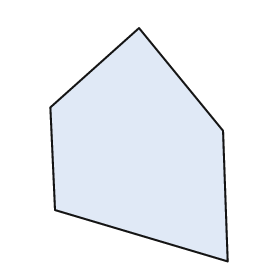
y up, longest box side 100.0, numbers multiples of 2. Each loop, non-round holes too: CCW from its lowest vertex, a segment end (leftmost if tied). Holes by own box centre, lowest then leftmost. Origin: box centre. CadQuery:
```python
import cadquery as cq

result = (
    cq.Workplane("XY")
    .moveTo(38.0, -50.0)
    .lineTo(36.0, 6.0)
    .lineTo(0.0, 50.0)
    .lineTo(-38.0, 16.0)
    .lineTo(-36.0, -28.0)
    .close()
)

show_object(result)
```